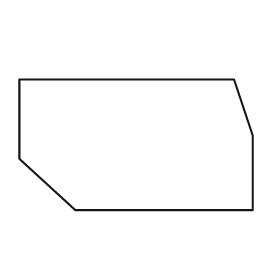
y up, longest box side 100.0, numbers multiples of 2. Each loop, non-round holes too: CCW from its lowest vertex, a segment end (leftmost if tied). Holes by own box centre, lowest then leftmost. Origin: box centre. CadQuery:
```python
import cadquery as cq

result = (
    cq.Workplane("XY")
    .moveTo(-26.0, -28.0)
    .lineTo(50.0, -28.0)
    .lineTo(50.0, 4.0)
    .lineTo(42.0, 28.0)
    .lineTo(-50.0, 28.0)
    .lineTo(-50.0, -6.0)
    .close()
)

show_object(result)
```